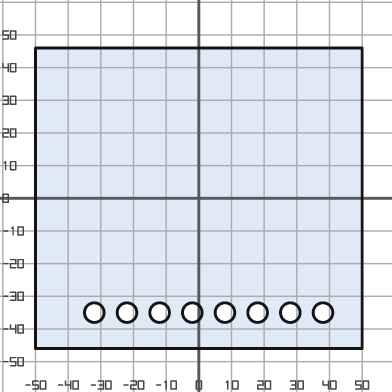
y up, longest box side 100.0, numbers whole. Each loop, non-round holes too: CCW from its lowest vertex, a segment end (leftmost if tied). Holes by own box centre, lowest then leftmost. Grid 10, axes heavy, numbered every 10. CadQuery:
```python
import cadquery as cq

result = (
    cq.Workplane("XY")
    .moveTo(-50.0, -46.0)
    .lineTo(50.0, -46.0)
    .lineTo(50.0, 46.0)
    .lineTo(-50.0, 46.0)
    .close()
    .moveTo(-32.0, -35.0)
    .circle(3.0)
    .moveTo(-22.0, -35.0)
    .circle(3.0)
    .moveTo(-12.0, -35.0)
    .circle(3.0)
    .moveTo(-2.0, -35.0)
    .circle(3.0)
    .moveTo(8.0, -35.0)
    .circle(3.0)
    .moveTo(18.0, -35.0)
    .circle(3.0)
    .moveTo(28.0, -35.0)
    .circle(3.0)
    .moveTo(38.0, -35.0)
    .circle(3.0)
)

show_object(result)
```